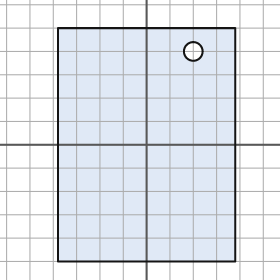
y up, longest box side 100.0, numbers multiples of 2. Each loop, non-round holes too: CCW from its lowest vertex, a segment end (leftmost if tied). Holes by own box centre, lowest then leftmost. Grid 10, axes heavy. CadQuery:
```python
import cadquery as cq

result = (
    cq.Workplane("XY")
    .moveTo(-38.0, -50.0)
    .lineTo(38.0, -50.0)
    .lineTo(38.0, 50.0)
    .lineTo(-38.0, 50.0)
    .close()
    .moveTo(20.0, 40.0)
    .circle(4.0)
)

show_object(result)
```